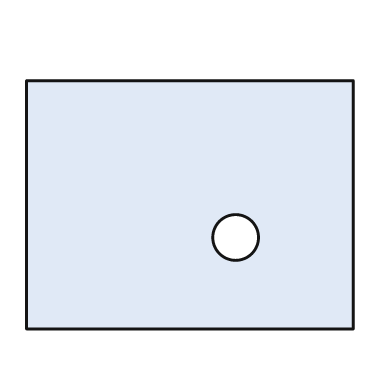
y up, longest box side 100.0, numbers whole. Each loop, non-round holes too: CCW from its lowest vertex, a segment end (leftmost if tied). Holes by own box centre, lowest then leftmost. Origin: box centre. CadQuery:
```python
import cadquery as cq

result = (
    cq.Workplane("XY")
    .moveTo(-50.0, -38.0)
    .lineTo(50.0, -38.0)
    .lineTo(50.0, 38.0)
    .lineTo(-50.0, 38.0)
    .close()
    .moveTo(14.0, -10.0)
    .circle(7.0)
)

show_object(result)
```